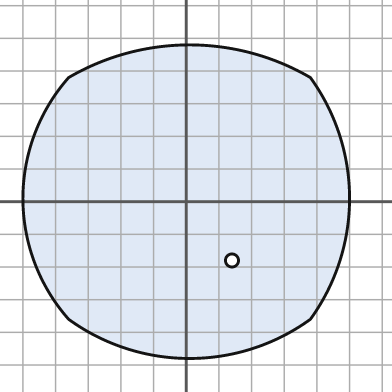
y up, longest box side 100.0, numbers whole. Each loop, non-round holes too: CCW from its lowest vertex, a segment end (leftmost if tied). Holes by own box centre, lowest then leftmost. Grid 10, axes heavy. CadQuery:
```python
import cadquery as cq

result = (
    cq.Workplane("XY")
    .moveTo(-36.0, -36.0)
    .threePointArc((1.0, -48.0), (38.0, -36.0))
    .threePointArc((50.0, 1.0), (38.0, 38.0))
    .threePointArc((1.0, 48.0), (-36.0, 38.0))
    .threePointArc((-50.0, 1.0), (-36.0, -36.0))
    .close()
    .moveTo(14.0, -18.0)
    .circle(2.0)
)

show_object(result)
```